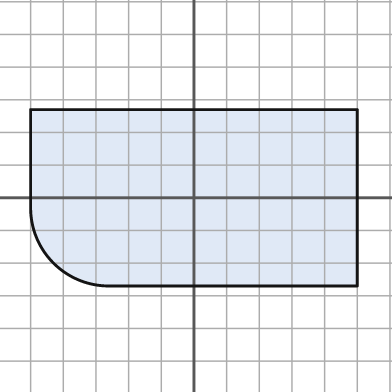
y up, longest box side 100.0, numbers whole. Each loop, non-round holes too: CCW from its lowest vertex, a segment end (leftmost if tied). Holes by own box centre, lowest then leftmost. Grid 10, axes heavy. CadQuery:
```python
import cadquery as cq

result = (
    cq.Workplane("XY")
    .moveTo(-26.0, -27.0)
    .lineTo(50.0, -27.0)
    .lineTo(50.0, 27.0)
    .lineTo(-50.0, 27.0)
    .lineTo(-50.0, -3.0)
    .threePointArc((-43.0, -20.0), (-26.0, -27.0))
    .close()
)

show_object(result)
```